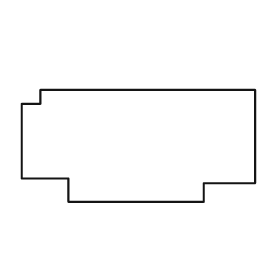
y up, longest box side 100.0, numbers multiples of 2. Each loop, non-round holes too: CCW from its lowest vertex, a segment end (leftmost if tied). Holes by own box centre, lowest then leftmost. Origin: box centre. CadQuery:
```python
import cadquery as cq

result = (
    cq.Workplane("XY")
    .moveTo(-30.0, -24.0)
    .lineTo(28.0, -24.0)
    .lineTo(28.0, -16.0)
    .lineTo(50.0, -16.0)
    .lineTo(50.0, 24.0)
    .lineTo(-42.0, 24.0)
    .lineTo(-42.0, 18.0)
    .lineTo(-50.0, 18.0)
    .lineTo(-50.0, -14.0)
    .lineTo(-30.0, -14.0)
    .close()
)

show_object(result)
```